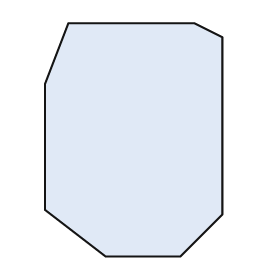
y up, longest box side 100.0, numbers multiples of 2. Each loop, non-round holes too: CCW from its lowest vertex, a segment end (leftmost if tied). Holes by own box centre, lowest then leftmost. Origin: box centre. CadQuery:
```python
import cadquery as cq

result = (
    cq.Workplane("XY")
    .moveTo(-12.0, -50.0)
    .lineTo(20.0, -50.0)
    .lineTo(38.0, -32.0)
    .lineTo(38.0, 44.0)
    .lineTo(26.0, 50.0)
    .lineTo(-28.0, 50.0)
    .lineTo(-38.0, 24.0)
    .lineTo(-38.0, -30.0)
    .close()
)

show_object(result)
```